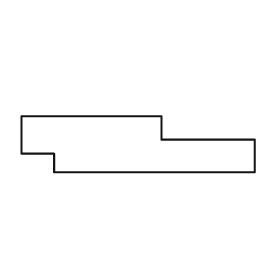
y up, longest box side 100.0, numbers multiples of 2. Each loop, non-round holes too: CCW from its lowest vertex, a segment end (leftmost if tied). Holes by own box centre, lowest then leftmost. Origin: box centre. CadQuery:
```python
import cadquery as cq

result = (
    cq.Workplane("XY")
    .moveTo(-36.0, -12.0)
    .lineTo(50.0, -12.0)
    .lineTo(50.0, 2.0)
    .lineTo(10.0, 2.0)
    .lineTo(10.0, 12.0)
    .lineTo(-50.0, 12.0)
    .lineTo(-50.0, -4.0)
    .lineTo(-36.0, -4.0)
    .close()
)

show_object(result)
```